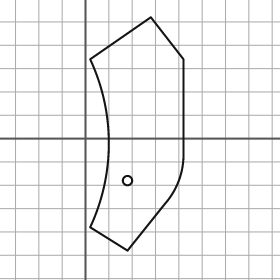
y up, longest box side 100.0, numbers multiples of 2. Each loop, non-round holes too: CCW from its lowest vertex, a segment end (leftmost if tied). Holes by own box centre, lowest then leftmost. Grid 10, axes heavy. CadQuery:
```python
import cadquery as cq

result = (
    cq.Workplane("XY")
    .moveTo(18.0, -48.0)
    .lineTo(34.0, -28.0)
    .threePointArc((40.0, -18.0), (42.0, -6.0))
    .lineTo(42.0, 34.0)
    .lineTo(28.0, 52.0)
    .lineTo(2.0, 34.0)
    .threePointArc((10.0, -2.0), (2.0, -38.0))
    .close()
    .moveTo(18.0, -18.0)
    .circle(2.0)
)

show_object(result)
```